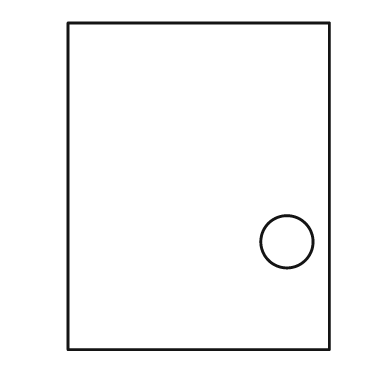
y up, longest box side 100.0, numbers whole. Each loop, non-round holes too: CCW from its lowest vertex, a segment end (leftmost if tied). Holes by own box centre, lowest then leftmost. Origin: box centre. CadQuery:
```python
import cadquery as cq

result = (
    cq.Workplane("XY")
    .moveTo(-40.0, -50.0)
    .lineTo(40.0, -50.0)
    .lineTo(40.0, 50.0)
    .lineTo(-40.0, 50.0)
    .close()
    .moveTo(27.0, -17.0)
    .circle(8.0)
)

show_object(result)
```